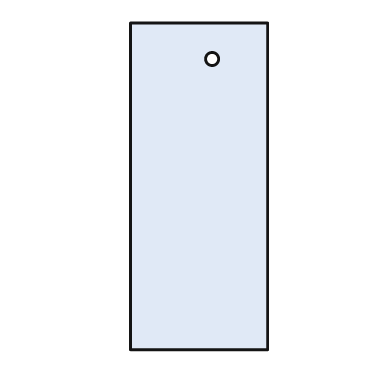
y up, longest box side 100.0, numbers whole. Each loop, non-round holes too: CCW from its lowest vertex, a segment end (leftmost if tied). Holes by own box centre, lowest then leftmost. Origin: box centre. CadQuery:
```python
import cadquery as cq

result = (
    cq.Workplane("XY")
    .moveTo(-21.0, -50.0)
    .lineTo(21.0, -50.0)
    .lineTo(21.0, 50.0)
    .lineTo(-21.0, 50.0)
    .close()
    .moveTo(4.0, 39.0)
    .circle(2.0)
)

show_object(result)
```